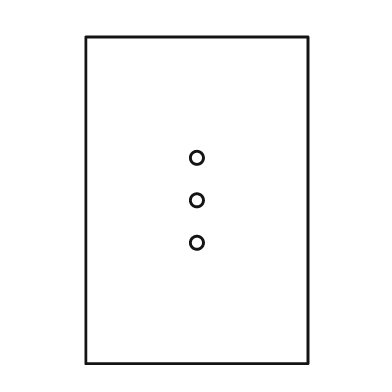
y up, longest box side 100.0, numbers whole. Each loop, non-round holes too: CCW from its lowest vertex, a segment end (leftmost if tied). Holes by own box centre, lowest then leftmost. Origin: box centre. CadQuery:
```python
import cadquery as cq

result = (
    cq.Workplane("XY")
    .moveTo(-34.0, -50.0)
    .lineTo(34.0, -50.0)
    .lineTo(34.0, 50.0)
    .lineTo(-34.0, 50.0)
    .close()
    .moveTo(0.0, -13.0)
    .circle(2.0)
    .moveTo(0.0, 0.0)
    .circle(2.0)
    .moveTo(0.0, 13.0)
    .circle(2.0)
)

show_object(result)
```